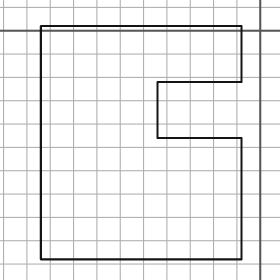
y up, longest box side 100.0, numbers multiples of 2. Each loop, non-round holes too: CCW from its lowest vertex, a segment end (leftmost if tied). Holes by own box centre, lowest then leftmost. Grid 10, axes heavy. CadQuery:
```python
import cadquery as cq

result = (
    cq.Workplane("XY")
    .moveTo(-94.0, -98.0)
    .lineTo(-8.0, -98.0)
    .lineTo(-8.0, -46.0)
    .lineTo(-44.0, -46.0)
    .lineTo(-44.0, -22.0)
    .lineTo(-8.0, -22.0)
    .lineTo(-8.0, 2.0)
    .lineTo(-94.0, 2.0)
    .close()
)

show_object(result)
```